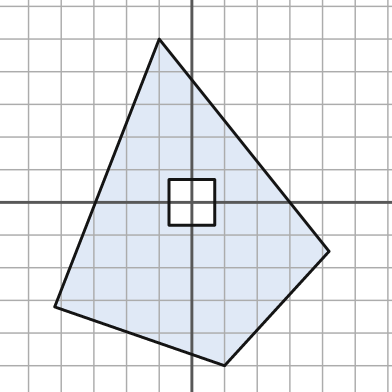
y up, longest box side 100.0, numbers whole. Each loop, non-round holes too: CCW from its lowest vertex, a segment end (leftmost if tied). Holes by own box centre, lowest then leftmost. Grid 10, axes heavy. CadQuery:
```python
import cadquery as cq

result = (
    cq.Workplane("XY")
    .moveTo(10.0, -50.0)
    .lineTo(42.0, -15.0)
    .lineTo(-10.0, 50.0)
    .lineTo(-42.0, -32.0)
    .close()
    .moveTo(-7.0, -7.0)
    .lineTo(7.0, -7.0)
    .lineTo(7.0, 7.0)
    .lineTo(-7.0, 7.0)
    .close()
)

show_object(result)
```